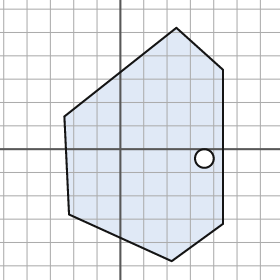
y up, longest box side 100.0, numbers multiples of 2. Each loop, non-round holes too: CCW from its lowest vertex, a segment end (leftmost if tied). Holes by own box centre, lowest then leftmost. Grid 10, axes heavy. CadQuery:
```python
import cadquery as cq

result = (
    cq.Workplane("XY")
    .moveTo(22.0, -48.0)
    .lineTo(44.0, -32.0)
    .lineTo(44.0, 34.0)
    .lineTo(24.0, 52.0)
    .lineTo(-24.0, 14.0)
    .lineTo(-22.0, -28.0)
    .close()
    .moveTo(36.0, -4.0)
    .circle(4.0)
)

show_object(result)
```